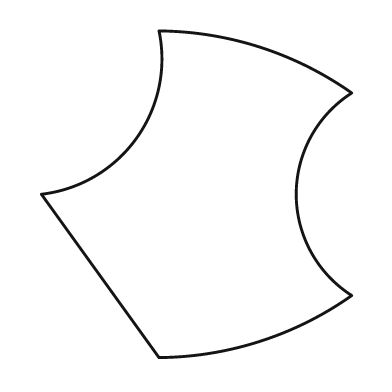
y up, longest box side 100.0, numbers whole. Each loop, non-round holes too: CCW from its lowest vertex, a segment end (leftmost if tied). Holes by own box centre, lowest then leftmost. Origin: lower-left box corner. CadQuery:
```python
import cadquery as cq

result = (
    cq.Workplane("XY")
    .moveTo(36.0, 0.0)
    .threePointArc((67.0, 5.0), (95.0, 19.0))
    .threePointArc((78.0, 50.0), (95.0, 81.0))
    .threePointArc((67.0, 95.0), (36.0, 100.0))
    .threePointArc((29.0, 67.0), (0.0, 50.0))
    .close()
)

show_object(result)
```